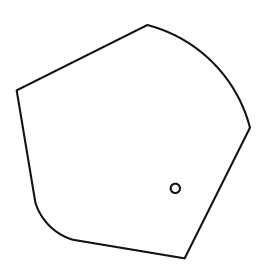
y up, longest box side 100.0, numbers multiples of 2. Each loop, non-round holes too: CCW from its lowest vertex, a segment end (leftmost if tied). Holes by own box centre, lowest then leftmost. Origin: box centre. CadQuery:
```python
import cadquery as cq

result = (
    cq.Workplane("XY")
    .moveTo(22.0, -50.0)
    .lineTo(50.0, 6.0)
    .threePointArc((34.0, 34.0), (6.0, 50.0))
    .lineTo(-50.0, 22.0)
    .lineTo(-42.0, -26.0)
    .threePointArc((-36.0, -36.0), (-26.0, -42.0))
    .close()
    .moveTo(18.0, -20.0)
    .circle(2.0)
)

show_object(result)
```